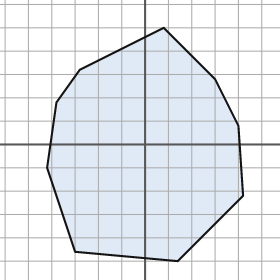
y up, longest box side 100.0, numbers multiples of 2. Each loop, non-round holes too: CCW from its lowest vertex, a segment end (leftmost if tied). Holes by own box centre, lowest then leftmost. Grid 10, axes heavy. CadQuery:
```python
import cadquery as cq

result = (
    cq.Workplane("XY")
    .moveTo(14.0, -50.0)
    .lineTo(42.0, -22.0)
    .lineTo(40.0, 8.0)
    .lineTo(30.0, 28.0)
    .lineTo(8.0, 50.0)
    .lineTo(-28.0, 32.0)
    .lineTo(-38.0, 18.0)
    .lineTo(-42.0, -10.0)
    .lineTo(-30.0, -46.0)
    .close()
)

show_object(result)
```